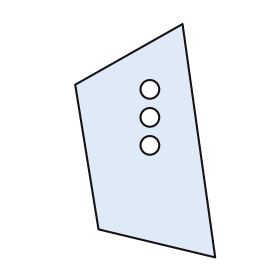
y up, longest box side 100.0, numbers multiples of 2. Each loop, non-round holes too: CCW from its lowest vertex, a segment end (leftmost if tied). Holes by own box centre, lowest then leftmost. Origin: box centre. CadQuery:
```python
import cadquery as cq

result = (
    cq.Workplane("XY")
    .moveTo(30.0, -50.0)
    .lineTo(16.0, 50.0)
    .lineTo(-30.0, 24.0)
    .lineTo(-20.0, -38.0)
    .close()
    .moveTo(2.0, -2.0)
    .circle(4.0)
    .moveTo(2.0, 10.0)
    .circle(4.0)
    .moveTo(2.0, 22.0)
    .circle(4.0)
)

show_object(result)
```